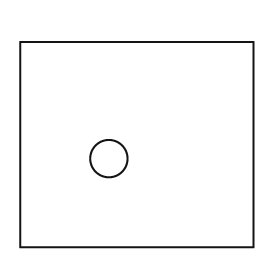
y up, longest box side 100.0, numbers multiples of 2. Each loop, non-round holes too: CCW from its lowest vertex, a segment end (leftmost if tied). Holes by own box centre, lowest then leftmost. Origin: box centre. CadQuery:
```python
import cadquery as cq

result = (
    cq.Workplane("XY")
    .moveTo(-50.0, -44.0)
    .lineTo(50.0, -44.0)
    .lineTo(50.0, 44.0)
    .lineTo(-50.0, 44.0)
    .close()
    .moveTo(-12.0, -6.0)
    .circle(8.0)
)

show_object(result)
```